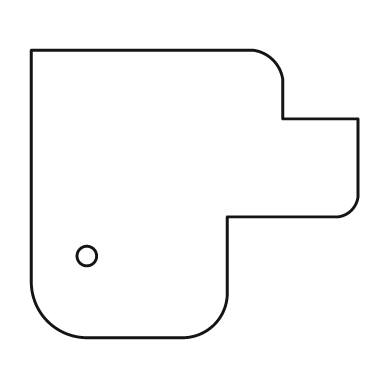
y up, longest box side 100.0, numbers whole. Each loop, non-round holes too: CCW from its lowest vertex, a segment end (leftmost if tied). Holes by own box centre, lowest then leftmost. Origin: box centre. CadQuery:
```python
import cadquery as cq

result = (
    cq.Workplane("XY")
    .moveTo(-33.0, -44.0)
    .lineTo(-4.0, -44.0)
    .threePointArc((6.0, -40.0), (10.0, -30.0))
    .lineTo(10.0, -7.0)
    .lineTo(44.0, -7.0)
    .threePointArc((48.0, -5.0), (50.0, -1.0))
    .lineTo(50.0, 23.0)
    .lineTo(27.0, 23.0)
    .lineTo(27.0, 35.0)
    .threePointArc((24.0, 41.0), (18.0, 44.0))
    .lineTo(-50.0, 44.0)
    .lineTo(-50.0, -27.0)
    .threePointArc((-45.0, -39.0), (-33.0, -44.0))
    .close()
    .moveTo(-33.0, -19.0)
    .circle(3.0)
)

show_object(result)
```